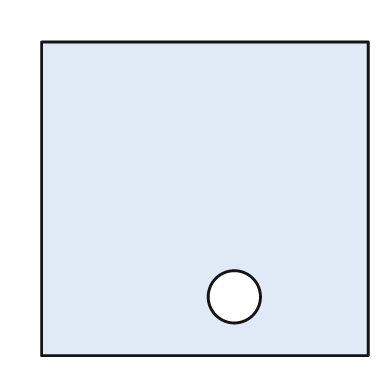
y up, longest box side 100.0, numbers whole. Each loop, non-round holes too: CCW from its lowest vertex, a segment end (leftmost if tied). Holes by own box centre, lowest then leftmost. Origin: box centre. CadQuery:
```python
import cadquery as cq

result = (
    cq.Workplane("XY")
    .moveTo(-50.0, -48.0)
    .lineTo(50.0, -48.0)
    .lineTo(50.0, 48.0)
    .lineTo(-50.0, 48.0)
    .close()
    .moveTo(9.0, -30.0)
    .circle(8.0)
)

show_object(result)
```